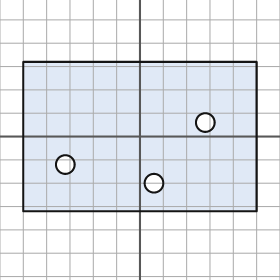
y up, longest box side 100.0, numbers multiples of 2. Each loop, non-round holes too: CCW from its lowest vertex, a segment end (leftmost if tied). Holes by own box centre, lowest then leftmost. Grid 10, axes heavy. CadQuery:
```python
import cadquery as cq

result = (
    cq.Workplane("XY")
    .moveTo(-50.0, -32.0)
    .lineTo(50.0, -32.0)
    .lineTo(50.0, 32.0)
    .lineTo(-50.0, 32.0)
    .close()
    .moveTo(6.0, -20.0)
    .circle(4.0)
    .moveTo(-32.0, -12.0)
    .circle(4.0)
    .moveTo(28.0, 6.0)
    .circle(4.0)
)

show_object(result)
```